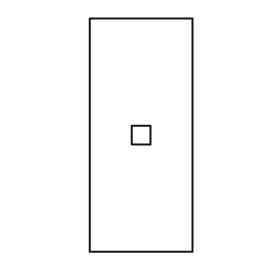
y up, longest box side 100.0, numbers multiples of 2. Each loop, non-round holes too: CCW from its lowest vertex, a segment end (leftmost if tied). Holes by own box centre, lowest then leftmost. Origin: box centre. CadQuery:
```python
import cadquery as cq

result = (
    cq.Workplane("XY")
    .moveTo(-22.0, -50.0)
    .lineTo(22.0, -50.0)
    .lineTo(22.0, 50.0)
    .lineTo(-22.0, 50.0)
    .close()
    .moveTo(-4.0, -4.0)
    .lineTo(4.0, -4.0)
    .lineTo(4.0, 4.0)
    .lineTo(-4.0, 4.0)
    .close()
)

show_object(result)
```